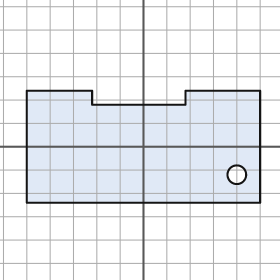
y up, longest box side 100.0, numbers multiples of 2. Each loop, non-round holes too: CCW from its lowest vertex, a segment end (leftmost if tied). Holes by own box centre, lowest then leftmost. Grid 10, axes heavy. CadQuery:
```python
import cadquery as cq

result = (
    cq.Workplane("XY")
    .moveTo(-50.0, -24.0)
    .lineTo(50.0, -24.0)
    .lineTo(50.0, 24.0)
    .lineTo(18.0, 24.0)
    .lineTo(18.0, 18.0)
    .lineTo(-22.0, 18.0)
    .lineTo(-22.0, 24.0)
    .lineTo(-50.0, 24.0)
    .close()
    .moveTo(40.0, -12.0)
    .circle(4.0)
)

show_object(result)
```